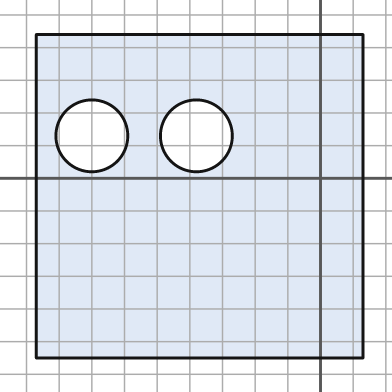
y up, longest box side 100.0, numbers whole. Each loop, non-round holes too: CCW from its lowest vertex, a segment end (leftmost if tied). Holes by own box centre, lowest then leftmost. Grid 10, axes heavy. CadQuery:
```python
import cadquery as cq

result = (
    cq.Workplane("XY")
    .moveTo(-87.0, -55.0)
    .lineTo(13.0, -55.0)
    .lineTo(13.0, 44.0)
    .lineTo(-87.0, 44.0)
    .close()
    .moveTo(-70.0, 13.0)
    .circle(11.0)
    .moveTo(-38.0, 13.0)
    .circle(11.0)
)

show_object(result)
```